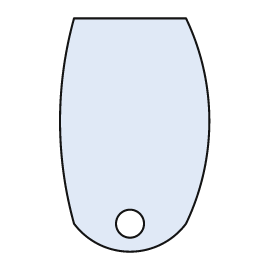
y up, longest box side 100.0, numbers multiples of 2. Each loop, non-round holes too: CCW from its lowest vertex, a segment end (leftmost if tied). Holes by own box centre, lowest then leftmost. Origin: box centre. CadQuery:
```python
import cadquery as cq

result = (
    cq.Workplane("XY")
    .moveTo(-26.0, -38.0)
    .threePointArc((-2.0, -50.0), (22.0, -38.0))
    .threePointArc((32.0, 6.0), (22.0, 50.0))
    .lineTo(-26.0, 50.0)
    .threePointArc((-32.0, 6.0), (-26.0, -38.0))
    .close()
    .moveTo(-2.0, -38.0)
    .circle(6.0)
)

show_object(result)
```